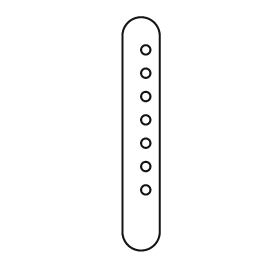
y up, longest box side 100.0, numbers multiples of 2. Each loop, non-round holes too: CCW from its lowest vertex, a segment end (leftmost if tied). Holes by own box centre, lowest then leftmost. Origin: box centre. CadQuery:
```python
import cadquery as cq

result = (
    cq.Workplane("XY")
    .moveTo(-8.0, -42.0)
    .threePointArc((0.0, -50.0), (8.0, -42.0))
    .lineTo(8.0, 42.0)
    .threePointArc((0.0, 50.0), (-8.0, 42.0))
    .close()
    .moveTo(2.0, -24.0)
    .circle(2.0)
    .moveTo(2.0, -14.0)
    .circle(2.0)
    .moveTo(2.0, -4.0)
    .circle(2.0)
    .moveTo(2.0, 6.0)
    .circle(2.0)
    .moveTo(2.0, 16.0)
    .circle(2.0)
    .moveTo(2.0, 26.0)
    .circle(2.0)
    .moveTo(2.0, 36.0)
    .circle(2.0)
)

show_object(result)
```